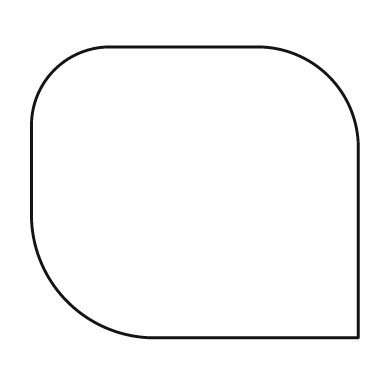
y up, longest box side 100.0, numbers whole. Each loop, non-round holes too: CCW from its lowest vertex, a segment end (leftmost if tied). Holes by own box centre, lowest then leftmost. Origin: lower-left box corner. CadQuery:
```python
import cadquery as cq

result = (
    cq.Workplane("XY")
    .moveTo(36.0, 0.0)
    .lineTo(100.0, 0.0)
    .lineTo(100.0, 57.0)
    .threePointArc((91.0, 80.0), (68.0, 89.0))
    .lineTo(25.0, 89.0)
    .threePointArc((7.0, 82.0), (0.0, 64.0))
    .lineTo(0.0, 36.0)
    .threePointArc((11.0, 11.0), (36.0, 0.0))
    .close()
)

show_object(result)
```